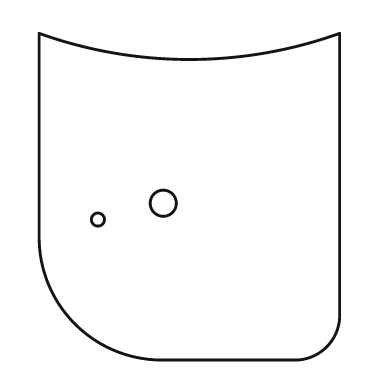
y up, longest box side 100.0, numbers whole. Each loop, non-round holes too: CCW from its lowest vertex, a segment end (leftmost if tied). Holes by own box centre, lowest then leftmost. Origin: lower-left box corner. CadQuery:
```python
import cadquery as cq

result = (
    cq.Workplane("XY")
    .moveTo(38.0, 0.0)
    .lineTo(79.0, 0.0)
    .threePointArc((88.0, 4.0), (92.0, 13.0))
    .lineTo(92.0, 100.0)
    .threePointArc((46.0, 92.0), (0.0, 100.0))
    .lineTo(0.0, 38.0)
    .threePointArc((11.0, 11.0), (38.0, 0.0))
    .close()
    .moveTo(18.0, 43.0)
    .circle(2.0)
    .moveTo(38.0, 48.0)
    .circle(4.0)
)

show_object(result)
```